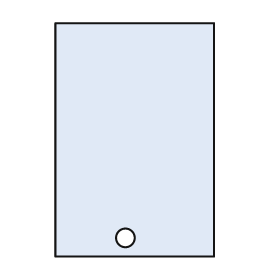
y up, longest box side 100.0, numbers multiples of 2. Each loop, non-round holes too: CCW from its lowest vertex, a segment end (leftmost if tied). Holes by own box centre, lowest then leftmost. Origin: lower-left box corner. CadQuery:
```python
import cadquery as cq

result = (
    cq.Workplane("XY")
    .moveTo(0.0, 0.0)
    .lineTo(68.0, 0.0)
    .lineTo(68.0, 100.0)
    .lineTo(0.0, 100.0)
    .close()
    .moveTo(30.0, 8.0)
    .circle(4.0)
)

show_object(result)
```